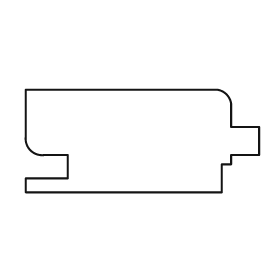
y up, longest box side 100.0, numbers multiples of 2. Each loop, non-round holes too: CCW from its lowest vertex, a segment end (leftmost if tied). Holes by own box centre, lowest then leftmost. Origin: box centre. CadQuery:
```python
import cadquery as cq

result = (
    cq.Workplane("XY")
    .moveTo(-50.0, -22.0)
    .lineTo(34.0, -22.0)
    .lineTo(34.0, -10.0)
    .lineTo(38.0, -10.0)
    .lineTo(38.0, -6.0)
    .lineTo(50.0, -6.0)
    .lineTo(50.0, 6.0)
    .lineTo(38.0, 6.0)
    .lineTo(38.0, 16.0)
    .threePointArc((36.0, 20.0), (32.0, 22.0))
    .lineTo(-50.0, 22.0)
    .lineTo(-50.0, 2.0)
    .threePointArc((-48.0, -4.0), (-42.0, -6.0))
    .lineTo(-32.0, -6.0)
    .lineTo(-32.0, -16.0)
    .lineTo(-50.0, -16.0)
    .close()
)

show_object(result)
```